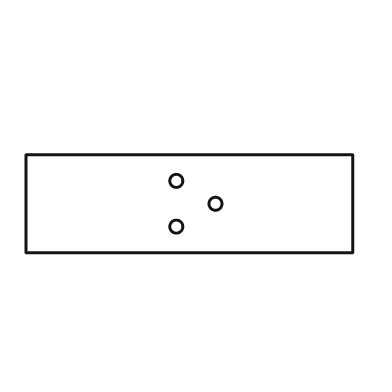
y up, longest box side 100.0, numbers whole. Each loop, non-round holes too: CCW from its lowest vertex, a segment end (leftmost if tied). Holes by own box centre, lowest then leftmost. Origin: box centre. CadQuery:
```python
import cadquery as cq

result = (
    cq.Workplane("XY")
    .moveTo(-50.0, -15.0)
    .lineTo(50.0, -15.0)
    .lineTo(50.0, 15.0)
    .lineTo(-50.0, 15.0)
    .close()
    .moveTo(-4.0, -7.0)
    .circle(2.0)
    .moveTo(8.0, 0.0)
    .circle(2.0)
    .moveTo(-4.0, 7.0)
    .circle(2.0)
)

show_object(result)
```